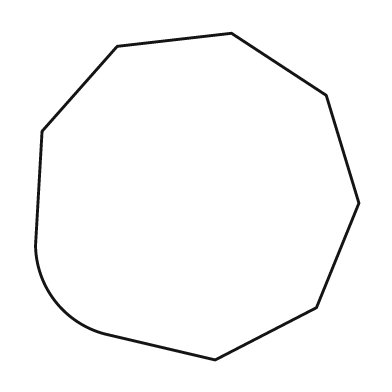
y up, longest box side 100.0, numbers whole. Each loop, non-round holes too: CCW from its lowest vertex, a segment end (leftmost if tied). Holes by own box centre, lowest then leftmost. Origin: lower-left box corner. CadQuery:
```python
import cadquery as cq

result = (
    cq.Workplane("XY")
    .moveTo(55.0, 0.0)
    .lineTo(86.0, 16.0)
    .lineTo(99.0, 48.0)
    .lineTo(89.0, 81.0)
    .lineTo(60.0, 100.0)
    .lineTo(25.0, 96.0)
    .lineTo(2.0, 70.0)
    .lineTo(0.0, 35.0)
    .threePointArc((6.0, 18.0), (21.0, 8.0))
    .close()
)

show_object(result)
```